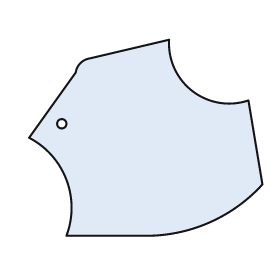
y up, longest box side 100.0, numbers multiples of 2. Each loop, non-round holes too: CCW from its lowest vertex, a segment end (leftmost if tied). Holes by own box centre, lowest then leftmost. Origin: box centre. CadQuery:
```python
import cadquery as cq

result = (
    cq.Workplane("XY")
    .moveTo(-34.0, -42.0)
    .lineTo(2.0, -42.0)
    .threePointArc((28.0, -36.0), (50.0, -20.0))
    .lineTo(44.0, 16.0)
    .threePointArc((20.0, 20.0), (10.0, 42.0))
    .lineTo(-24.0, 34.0)
    .threePointArc((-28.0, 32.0), (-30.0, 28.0))
    .lineTo(-50.0, 0.0)
    .threePointArc((-34.0, -18.0), (-34.0, -42.0))
    .close()
    .moveTo(-36.0, 6.0)
    .circle(2.0)
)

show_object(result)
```